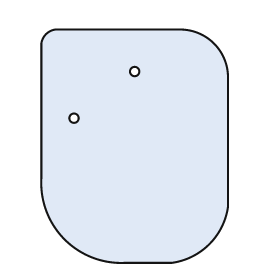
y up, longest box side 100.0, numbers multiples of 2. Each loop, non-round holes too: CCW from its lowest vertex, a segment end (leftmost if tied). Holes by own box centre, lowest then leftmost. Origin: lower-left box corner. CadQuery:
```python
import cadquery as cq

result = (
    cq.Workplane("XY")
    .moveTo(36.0, 0.0)
    .lineTo(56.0, 0.0)
    .threePointArc((72.0, 8.0), (80.0, 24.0))
    .lineTo(80.0, 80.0)
    .threePointArc((74.0, 94.0), (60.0, 100.0))
    .lineTo(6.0, 100.0)
    .threePointArc((2.0, 98.0), (0.0, 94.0))
    .lineTo(0.0, 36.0)
    .threePointArc((10.0, 10.0), (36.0, 0.0))
    .close()
    .moveTo(14.0, 62.0)
    .circle(2.0)
    .moveTo(40.0, 82.0)
    .circle(2.0)
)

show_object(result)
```